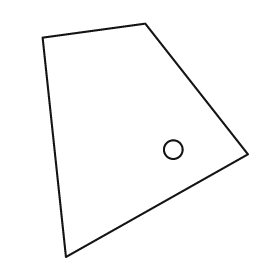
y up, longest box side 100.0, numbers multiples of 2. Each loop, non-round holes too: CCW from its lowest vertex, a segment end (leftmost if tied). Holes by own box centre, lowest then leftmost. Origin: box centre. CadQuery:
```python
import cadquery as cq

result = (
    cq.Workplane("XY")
    .moveTo(-34.0, -50.0)
    .lineTo(44.0, -6.0)
    .lineTo(0.0, 50.0)
    .lineTo(-44.0, 44.0)
    .close()
    .moveTo(12.0, -4.0)
    .circle(4.0)
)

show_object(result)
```